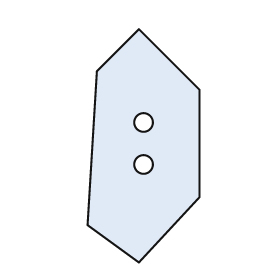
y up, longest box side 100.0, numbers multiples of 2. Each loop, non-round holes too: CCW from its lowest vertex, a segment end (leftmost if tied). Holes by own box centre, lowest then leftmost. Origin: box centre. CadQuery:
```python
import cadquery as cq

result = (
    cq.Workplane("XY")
    .moveTo(-2.0, -50.0)
    .lineTo(24.0, -22.0)
    .lineTo(24.0, 24.0)
    .lineTo(-2.0, 50.0)
    .lineTo(-20.0, 32.0)
    .lineTo(-24.0, -34.0)
    .close()
    .moveTo(0.0, -8.0)
    .circle(4.0)
    .moveTo(0.0, 10.0)
    .circle(4.0)
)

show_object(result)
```